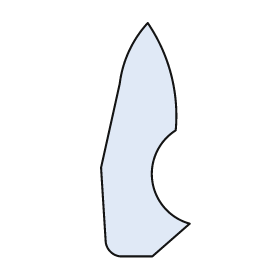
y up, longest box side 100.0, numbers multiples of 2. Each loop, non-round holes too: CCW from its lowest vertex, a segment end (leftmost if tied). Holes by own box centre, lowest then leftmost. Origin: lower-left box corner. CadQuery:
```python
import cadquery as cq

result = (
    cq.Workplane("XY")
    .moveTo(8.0, 0.0)
    .lineTo(22.0, 0.0)
    .lineTo(38.0, 14.0)
    .threePointArc((22.0, 32.0), (32.0, 54.0))
    .threePointArc((30.0, 78.0), (20.0, 100.0))
    .threePointArc((12.0, 88.0), (8.0, 74.0))
    .lineTo(0.0, 38.0)
    .lineTo(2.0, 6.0)
    .threePointArc((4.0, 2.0), (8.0, 0.0))
    .close()
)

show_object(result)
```